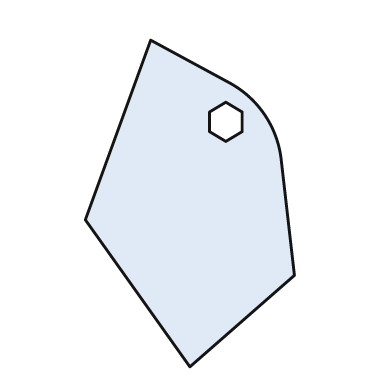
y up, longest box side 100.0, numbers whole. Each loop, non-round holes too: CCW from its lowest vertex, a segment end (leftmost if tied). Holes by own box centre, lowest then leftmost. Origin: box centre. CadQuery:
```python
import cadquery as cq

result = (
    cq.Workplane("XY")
    .moveTo(0.0, -50.0)
    .lineTo(32.0, -22.0)
    .lineTo(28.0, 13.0)
    .threePointArc((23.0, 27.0), (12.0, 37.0))
    .lineTo(-12.0, 50.0)
    .lineTo(-32.0, -5.0)
    .close()
    .moveTo(11.0, 19.0)
    .lineTo(16.0, 22.0)
    .lineTo(16.0, 28.0)
    .lineTo(11.0, 31.0)
    .lineTo(6.0, 28.0)
    .lineTo(6.0, 22.0)
    .close()
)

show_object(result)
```